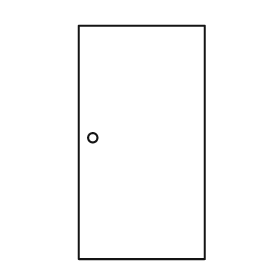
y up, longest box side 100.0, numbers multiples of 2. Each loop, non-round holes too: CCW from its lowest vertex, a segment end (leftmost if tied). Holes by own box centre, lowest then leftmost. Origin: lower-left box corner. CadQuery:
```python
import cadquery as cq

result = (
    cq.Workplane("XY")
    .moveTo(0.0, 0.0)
    .lineTo(54.0, 0.0)
    .lineTo(54.0, 100.0)
    .lineTo(0.0, 100.0)
    .close()
    .moveTo(6.0, 52.0)
    .circle(2.0)
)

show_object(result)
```